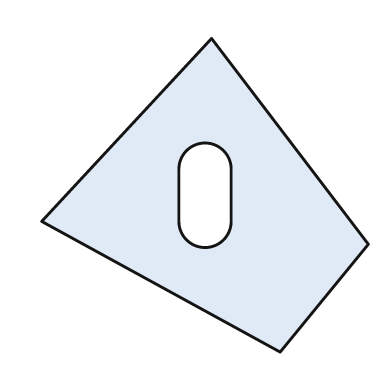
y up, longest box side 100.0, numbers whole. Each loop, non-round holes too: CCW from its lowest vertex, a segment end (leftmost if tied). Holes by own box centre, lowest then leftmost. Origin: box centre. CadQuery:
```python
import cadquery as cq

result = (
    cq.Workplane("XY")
    .moveTo(23.0, -48.0)
    .lineTo(50.0, -15.0)
    .lineTo(2.0, 48.0)
    .lineTo(-50.0, -8.0)
    .close()
    .moveTo(-8.0, -8.0)
    .threePointArc((0.0, -16.0), (8.0, -8.0))
    .lineTo(8.0, 8.0)
    .threePointArc((0.0, 16.0), (-8.0, 8.0))
    .close()
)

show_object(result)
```